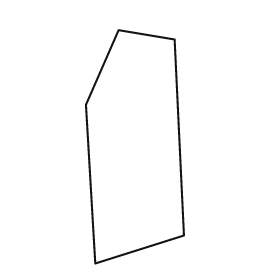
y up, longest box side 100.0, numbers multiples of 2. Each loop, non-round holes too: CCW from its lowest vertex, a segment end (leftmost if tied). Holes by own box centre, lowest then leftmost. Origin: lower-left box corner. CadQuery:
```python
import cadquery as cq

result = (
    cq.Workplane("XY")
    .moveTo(4.0, 0.0)
    .lineTo(42.0, 12.0)
    .lineTo(38.0, 96.0)
    .lineTo(14.0, 100.0)
    .lineTo(0.0, 68.0)
    .close()
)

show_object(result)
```